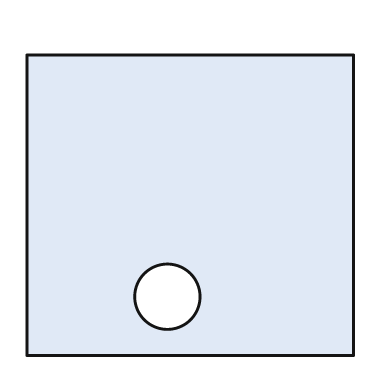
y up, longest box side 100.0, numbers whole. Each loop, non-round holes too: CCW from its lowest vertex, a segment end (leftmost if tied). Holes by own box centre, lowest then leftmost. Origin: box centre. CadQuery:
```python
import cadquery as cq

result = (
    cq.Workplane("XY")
    .moveTo(-50.0, -46.0)
    .lineTo(50.0, -46.0)
    .lineTo(50.0, 46.0)
    .lineTo(-50.0, 46.0)
    .close()
    .moveTo(-7.0, -28.0)
    .circle(10.0)
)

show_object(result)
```